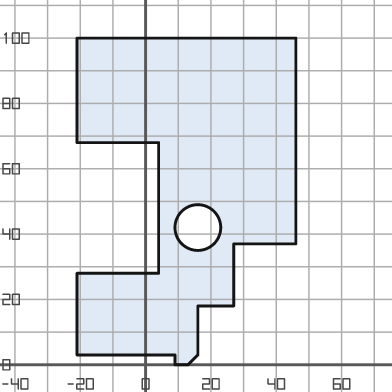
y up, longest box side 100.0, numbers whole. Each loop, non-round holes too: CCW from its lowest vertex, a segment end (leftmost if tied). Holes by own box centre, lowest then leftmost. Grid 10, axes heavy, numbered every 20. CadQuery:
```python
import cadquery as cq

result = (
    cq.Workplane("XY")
    .moveTo(9.0, 0.0)
    .lineTo(13.0, 0.0)
    .lineTo(16.0, 3.0)
    .lineTo(16.0, 18.0)
    .lineTo(27.0, 18.0)
    .lineTo(27.0, 37.0)
    .lineTo(46.0, 37.0)
    .lineTo(46.0, 100.0)
    .lineTo(-21.0, 100.0)
    .lineTo(-21.0, 68.0)
    .lineTo(4.0, 68.0)
    .lineTo(4.0, 28.0)
    .lineTo(-21.0, 28.0)
    .lineTo(-21.0, 3.0)
    .lineTo(9.0, 3.0)
    .close()
    .moveTo(16.0, 42.0)
    .circle(7.0)
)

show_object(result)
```